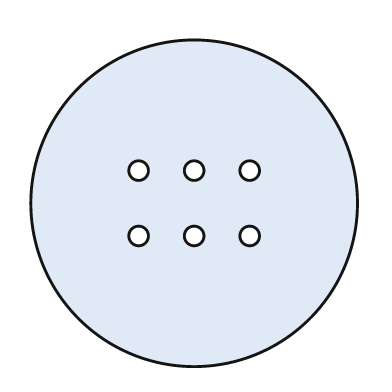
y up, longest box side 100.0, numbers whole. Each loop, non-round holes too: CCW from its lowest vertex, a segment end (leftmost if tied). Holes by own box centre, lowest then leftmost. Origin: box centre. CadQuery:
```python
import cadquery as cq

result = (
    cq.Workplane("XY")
    .moveTo(0.0, 0.0)
    .circle(50.0)
    .moveTo(-17.0, -10.0)
    .circle(3.0)
    .moveTo(0.0, -10.0)
    .circle(3.0)
    .moveTo(17.0, -10.0)
    .circle(3.0)
    .moveTo(-17.0, 10.0)
    .circle(3.0)
    .moveTo(0.0, 10.0)
    .circle(3.0)
    .moveTo(17.0, 10.0)
    .circle(3.0)
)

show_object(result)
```